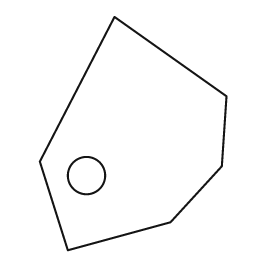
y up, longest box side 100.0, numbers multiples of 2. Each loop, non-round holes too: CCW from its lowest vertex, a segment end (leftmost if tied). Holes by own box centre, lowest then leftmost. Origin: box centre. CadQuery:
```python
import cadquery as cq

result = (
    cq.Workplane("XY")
    .moveTo(-28.0, -50.0)
    .lineTo(16.0, -38.0)
    .lineTo(38.0, -14.0)
    .lineTo(40.0, 16.0)
    .lineTo(-8.0, 50.0)
    .lineTo(-40.0, -12.0)
    .close()
    .moveTo(-20.0, -18.0)
    .circle(8.0)
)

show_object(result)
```